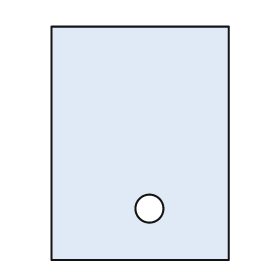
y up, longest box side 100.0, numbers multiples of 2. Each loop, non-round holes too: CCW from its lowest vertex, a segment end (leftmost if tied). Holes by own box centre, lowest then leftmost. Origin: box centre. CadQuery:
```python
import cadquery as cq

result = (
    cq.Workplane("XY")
    .moveTo(-38.0, -50.0)
    .lineTo(38.0, -50.0)
    .lineTo(38.0, 50.0)
    .lineTo(-38.0, 50.0)
    .close()
    .moveTo(4.0, -28.0)
    .circle(6.0)
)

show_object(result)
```